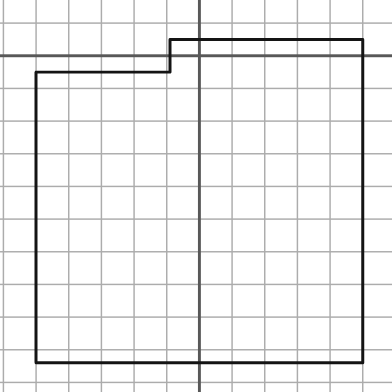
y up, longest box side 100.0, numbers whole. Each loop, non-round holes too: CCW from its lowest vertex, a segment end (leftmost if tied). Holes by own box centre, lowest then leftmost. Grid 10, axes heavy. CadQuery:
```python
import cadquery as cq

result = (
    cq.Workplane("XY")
    .moveTo(-50.0, -94.0)
    .lineTo(50.0, -94.0)
    .lineTo(50.0, 5.0)
    .lineTo(-9.0, 5.0)
    .lineTo(-9.0, -5.0)
    .lineTo(-50.0, -5.0)
    .close()
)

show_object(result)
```